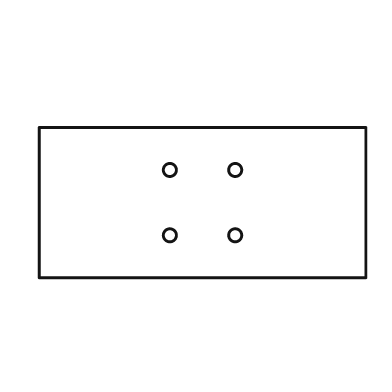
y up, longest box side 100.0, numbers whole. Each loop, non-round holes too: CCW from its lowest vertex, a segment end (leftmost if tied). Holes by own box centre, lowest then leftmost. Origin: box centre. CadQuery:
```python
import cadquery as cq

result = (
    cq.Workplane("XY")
    .moveTo(-50.0, -23.0)
    .lineTo(50.0, -23.0)
    .lineTo(50.0, 23.0)
    .lineTo(-50.0, 23.0)
    .close()
    .moveTo(-10.0, -10.0)
    .circle(2.0)
    .moveTo(10.0, -10.0)
    .circle(2.0)
    .moveTo(-10.0, 10.0)
    .circle(2.0)
    .moveTo(10.0, 10.0)
    .circle(2.0)
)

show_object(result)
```